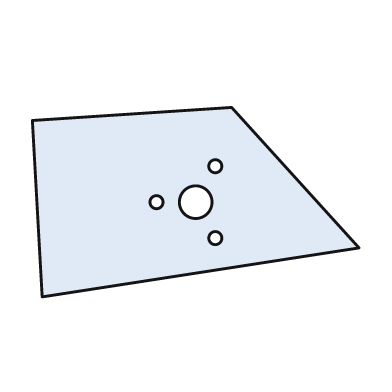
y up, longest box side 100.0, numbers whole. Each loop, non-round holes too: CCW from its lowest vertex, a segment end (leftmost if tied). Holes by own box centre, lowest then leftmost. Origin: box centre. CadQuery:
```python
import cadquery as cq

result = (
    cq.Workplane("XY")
    .moveTo(-47.0, -29.0)
    .lineTo(50.0, -14.0)
    .lineTo(11.0, 29.0)
    .lineTo(-50.0, 25.0)
    .close()
    .moveTo(6.0, -11.0)
    .circle(2.0)
    .moveTo(-12.0, 0.0)
    .circle(2.0)
    .moveTo(0.0, 0.0)
    .circle(5.0)
    .moveTo(6.0, 11.0)
    .circle(2.0)
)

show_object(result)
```